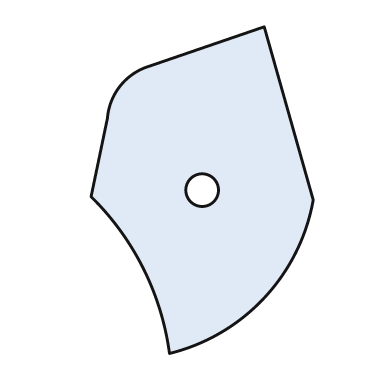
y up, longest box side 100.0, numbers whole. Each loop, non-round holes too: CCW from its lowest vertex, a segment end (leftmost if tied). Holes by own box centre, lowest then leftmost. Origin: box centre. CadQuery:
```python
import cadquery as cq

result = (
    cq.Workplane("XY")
    .moveTo(-10.0, -50.0)
    .threePointArc((19.0, -33.0), (34.0, -3.0))
    .lineTo(19.0, 50.0)
    .lineTo(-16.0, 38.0)
    .threePointArc((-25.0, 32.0), (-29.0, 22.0))
    .lineTo(-34.0, -2.0)
    .threePointArc((-18.0, -24.0), (-10.0, -50.0))
    .close()
    .moveTo(0.0, 0.0)
    .circle(5.0)
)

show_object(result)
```